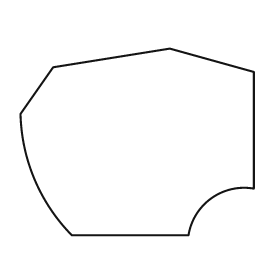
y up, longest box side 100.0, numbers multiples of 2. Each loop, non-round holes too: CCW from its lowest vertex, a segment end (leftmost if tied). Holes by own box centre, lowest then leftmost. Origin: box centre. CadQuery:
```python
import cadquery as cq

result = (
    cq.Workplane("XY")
    .moveTo(-28.0, -40.0)
    .lineTo(22.0, -40.0)
    .threePointArc((32.0, -24.0), (50.0, -20.0))
    .lineTo(50.0, 30.0)
    .lineTo(14.0, 40.0)
    .lineTo(-36.0, 32.0)
    .lineTo(-50.0, 12.0)
    .threePointArc((-44.0, -16.0), (-28.0, -40.0))
    .close()
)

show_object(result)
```